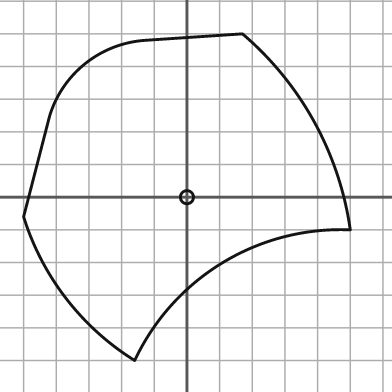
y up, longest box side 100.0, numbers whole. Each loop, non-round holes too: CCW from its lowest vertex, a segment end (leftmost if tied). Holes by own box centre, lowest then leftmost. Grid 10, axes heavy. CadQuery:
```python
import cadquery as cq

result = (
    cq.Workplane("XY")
    .moveTo(-16.0, -50.0)
    .threePointArc((11.0, -20.0), (50.0, -10.0))
    .threePointArc((39.0, 23.0), (17.0, 50.0))
    .lineTo(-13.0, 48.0)
    .threePointArc((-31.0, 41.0), (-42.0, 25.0))
    .lineTo(-50.0, -6.0)
    .threePointArc((-37.0, -31.0), (-16.0, -50.0))
    .close()
    .moveTo(0.0, 0.0)
    .circle(2.0)
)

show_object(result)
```